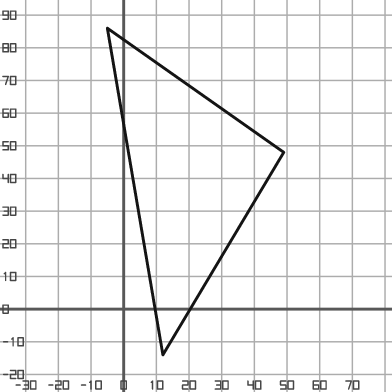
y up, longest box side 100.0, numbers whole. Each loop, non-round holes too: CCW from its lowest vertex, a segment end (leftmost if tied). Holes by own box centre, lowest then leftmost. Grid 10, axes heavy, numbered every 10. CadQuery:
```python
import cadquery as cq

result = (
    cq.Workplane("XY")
    .moveTo(12.0, -14.0)
    .lineTo(49.0, 48.0)
    .lineTo(-5.0, 86.0)
    .close()
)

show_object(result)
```